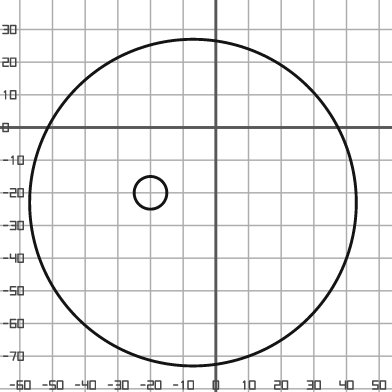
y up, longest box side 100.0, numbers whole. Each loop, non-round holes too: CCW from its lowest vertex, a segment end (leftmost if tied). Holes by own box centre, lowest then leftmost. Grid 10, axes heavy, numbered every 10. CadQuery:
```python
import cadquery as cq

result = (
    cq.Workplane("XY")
    .moveTo(-7.0, -23.0)
    .circle(50.0)
    .moveTo(-20.0, -20.0)
    .circle(5.0)
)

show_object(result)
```